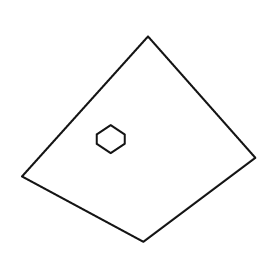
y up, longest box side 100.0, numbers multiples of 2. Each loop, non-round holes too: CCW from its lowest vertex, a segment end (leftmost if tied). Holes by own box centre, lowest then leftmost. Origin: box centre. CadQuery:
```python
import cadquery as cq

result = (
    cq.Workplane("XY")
    .moveTo(2.0, -44.0)
    .lineTo(50.0, -8.0)
    .lineTo(4.0, 44.0)
    .lineTo(-50.0, -16.0)
    .close()
    .moveTo(-12.0, -6.0)
    .lineTo(-6.0, -2.0)
    .lineTo(-6.0, 2.0)
    .lineTo(-12.0, 6.0)
    .lineTo(-18.0, 2.0)
    .lineTo(-18.0, -2.0)
    .close()
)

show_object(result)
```